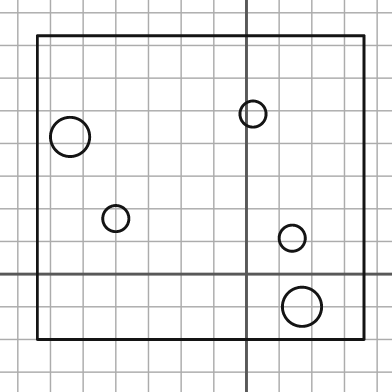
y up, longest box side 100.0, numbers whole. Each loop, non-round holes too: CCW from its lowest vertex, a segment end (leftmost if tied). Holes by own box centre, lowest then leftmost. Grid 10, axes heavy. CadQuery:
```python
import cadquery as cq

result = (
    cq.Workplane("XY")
    .moveTo(-64.0, -20.0)
    .lineTo(36.0, -20.0)
    .lineTo(36.0, 73.0)
    .lineTo(-64.0, 73.0)
    .close()
    .moveTo(17.0, -10.0)
    .circle(6.0)
    .moveTo(14.0, 11.0)
    .circle(4.0)
    .moveTo(-40.0, 17.0)
    .circle(4.0)
    .moveTo(-54.0, 42.0)
    .circle(6.0)
    .moveTo(2.0, 49.0)
    .circle(4.0)
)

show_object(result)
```